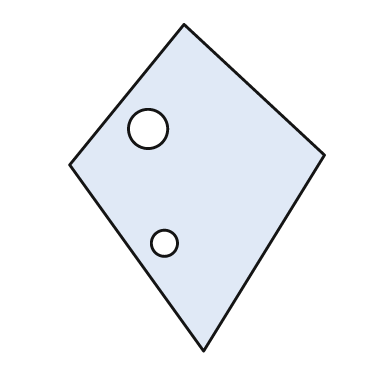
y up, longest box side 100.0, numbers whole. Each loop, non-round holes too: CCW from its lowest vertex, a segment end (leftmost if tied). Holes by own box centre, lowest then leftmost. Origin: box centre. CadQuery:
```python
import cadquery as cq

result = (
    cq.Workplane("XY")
    .moveTo(2.0, -50.0)
    .lineTo(39.0, 10.0)
    .lineTo(-4.0, 50.0)
    .lineTo(-39.0, 7.0)
    .close()
    .moveTo(-10.0, -17.0)
    .circle(4.0)
    .moveTo(-15.0, 18.0)
    .circle(6.0)
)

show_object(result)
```